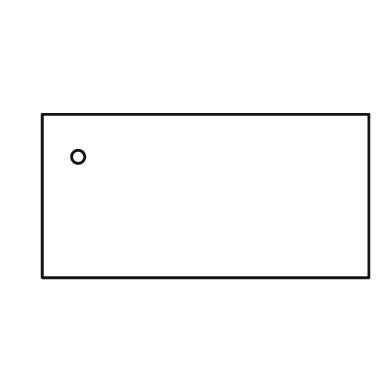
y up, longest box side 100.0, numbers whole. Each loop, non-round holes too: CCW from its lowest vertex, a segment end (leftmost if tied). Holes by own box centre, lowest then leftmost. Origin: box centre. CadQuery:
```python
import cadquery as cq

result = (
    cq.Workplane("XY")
    .moveTo(-50.0, -25.0)
    .lineTo(50.0, -25.0)
    .lineTo(50.0, 25.0)
    .lineTo(-50.0, 25.0)
    .close()
    .moveTo(-39.0, 12.0)
    .circle(2.0)
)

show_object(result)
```